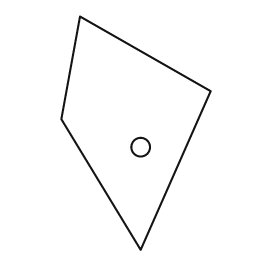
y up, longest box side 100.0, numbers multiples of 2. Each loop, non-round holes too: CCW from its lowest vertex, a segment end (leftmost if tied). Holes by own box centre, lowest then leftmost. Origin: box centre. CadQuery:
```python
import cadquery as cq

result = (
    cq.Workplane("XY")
    .moveTo(2.0, -50.0)
    .lineTo(32.0, 18.0)
    .lineTo(-24.0, 50.0)
    .lineTo(-32.0, 6.0)
    .close()
    .moveTo(2.0, -6.0)
    .circle(4.0)
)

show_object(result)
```